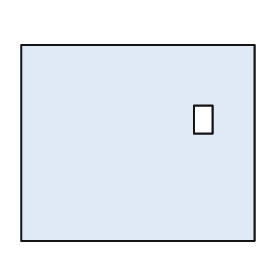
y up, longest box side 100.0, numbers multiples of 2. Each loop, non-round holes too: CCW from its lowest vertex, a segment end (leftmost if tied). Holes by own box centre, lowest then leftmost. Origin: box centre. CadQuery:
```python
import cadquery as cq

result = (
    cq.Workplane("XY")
    .moveTo(-50.0, -42.0)
    .lineTo(50.0, -42.0)
    .lineTo(50.0, 42.0)
    .lineTo(-50.0, 42.0)
    .close()
    .moveTo(24.0, 4.0)
    .lineTo(32.0, 4.0)
    .lineTo(32.0, 16.0)
    .lineTo(24.0, 16.0)
    .close()
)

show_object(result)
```